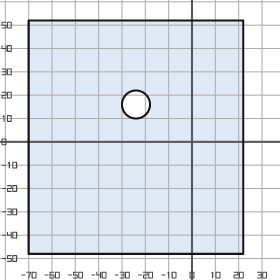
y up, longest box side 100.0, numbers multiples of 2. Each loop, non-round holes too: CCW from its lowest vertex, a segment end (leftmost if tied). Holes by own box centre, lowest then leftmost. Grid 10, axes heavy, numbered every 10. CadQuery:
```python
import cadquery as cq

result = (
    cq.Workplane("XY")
    .moveTo(-70.0, -48.0)
    .lineTo(22.0, -48.0)
    .lineTo(22.0, 52.0)
    .lineTo(-70.0, 52.0)
    .close()
    .moveTo(-24.0, 16.0)
    .circle(6.0)
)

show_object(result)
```